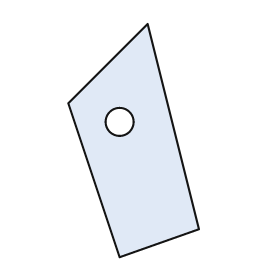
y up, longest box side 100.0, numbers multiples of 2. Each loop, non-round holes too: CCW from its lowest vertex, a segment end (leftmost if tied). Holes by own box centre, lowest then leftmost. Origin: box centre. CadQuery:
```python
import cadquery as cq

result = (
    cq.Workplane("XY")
    .moveTo(-6.0, -50.0)
    .lineTo(28.0, -38.0)
    .lineTo(6.0, 50.0)
    .lineTo(-28.0, 16.0)
    .close()
    .moveTo(-6.0, 8.0)
    .circle(6.0)
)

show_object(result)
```